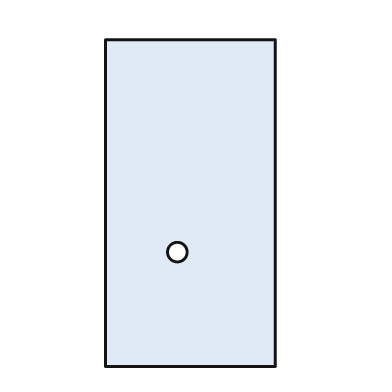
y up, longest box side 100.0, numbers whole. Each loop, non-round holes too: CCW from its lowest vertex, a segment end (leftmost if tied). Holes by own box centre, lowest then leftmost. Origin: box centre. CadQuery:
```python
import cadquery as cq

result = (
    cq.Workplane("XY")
    .moveTo(-26.0, -50.0)
    .lineTo(26.0, -50.0)
    .lineTo(26.0, 50.0)
    .lineTo(-26.0, 50.0)
    .close()
    .moveTo(-4.0, -15.0)
    .circle(3.0)
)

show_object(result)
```